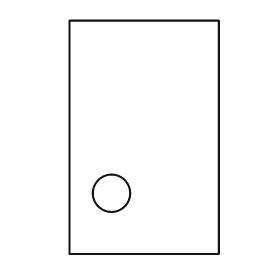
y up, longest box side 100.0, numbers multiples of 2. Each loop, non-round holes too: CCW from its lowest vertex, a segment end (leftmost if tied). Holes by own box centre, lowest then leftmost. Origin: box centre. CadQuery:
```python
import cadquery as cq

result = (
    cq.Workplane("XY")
    .moveTo(-32.0, -50.0)
    .lineTo(32.0, -50.0)
    .lineTo(32.0, 50.0)
    .lineTo(-32.0, 50.0)
    .close()
    .moveTo(-14.0, -24.0)
    .circle(8.0)
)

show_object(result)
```